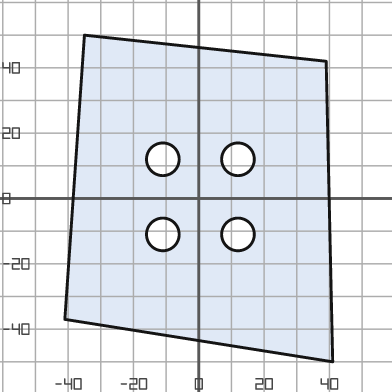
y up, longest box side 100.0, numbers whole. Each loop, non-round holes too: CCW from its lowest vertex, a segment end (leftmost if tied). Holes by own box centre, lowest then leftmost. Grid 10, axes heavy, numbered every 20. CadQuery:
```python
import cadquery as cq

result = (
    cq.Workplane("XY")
    .moveTo(41.0, -50.0)
    .lineTo(39.0, 42.0)
    .lineTo(-35.0, 50.0)
    .lineTo(-41.0, -37.0)
    .close()
    .moveTo(-11.0, -11.0)
    .circle(5.0)
    .moveTo(12.0, -11.0)
    .circle(5.0)
    .moveTo(-11.0, 12.0)
    .circle(5.0)
    .moveTo(12.0, 12.0)
    .circle(5.0)
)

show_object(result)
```